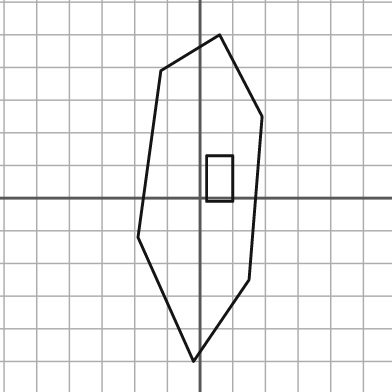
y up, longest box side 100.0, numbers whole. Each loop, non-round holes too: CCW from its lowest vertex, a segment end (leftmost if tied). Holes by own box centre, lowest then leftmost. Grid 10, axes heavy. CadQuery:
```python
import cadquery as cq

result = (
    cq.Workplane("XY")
    .moveTo(-2.0, -50.0)
    .lineTo(15.0, -25.0)
    .lineTo(19.0, 25.0)
    .lineTo(6.0, 50.0)
    .lineTo(-12.0, 39.0)
    .lineTo(-19.0, -12.0)
    .close()
    .moveTo(2.0, -1.0)
    .lineTo(10.0, -1.0)
    .lineTo(10.0, 13.0)
    .lineTo(2.0, 13.0)
    .close()
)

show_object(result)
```